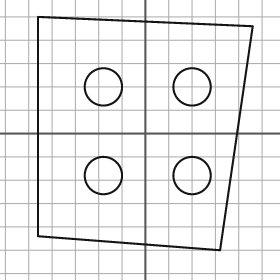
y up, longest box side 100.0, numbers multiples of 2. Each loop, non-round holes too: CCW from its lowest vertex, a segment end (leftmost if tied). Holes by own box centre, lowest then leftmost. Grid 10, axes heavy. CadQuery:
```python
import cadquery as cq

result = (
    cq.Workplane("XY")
    .moveTo(32.0, -50.0)
    .lineTo(46.0, 46.0)
    .lineTo(-46.0, 50.0)
    .lineTo(-46.0, -44.0)
    .close()
    .moveTo(-18.0, -18.0)
    .circle(8.0)
    .moveTo(20.0, -18.0)
    .circle(8.0)
    .moveTo(-18.0, 20.0)
    .circle(8.0)
    .moveTo(20.0, 20.0)
    .circle(8.0)
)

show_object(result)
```